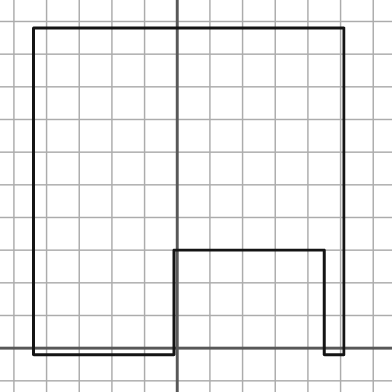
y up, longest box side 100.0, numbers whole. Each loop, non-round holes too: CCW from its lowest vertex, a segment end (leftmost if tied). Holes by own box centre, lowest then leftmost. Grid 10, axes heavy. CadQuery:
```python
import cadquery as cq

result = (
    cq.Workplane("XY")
    .moveTo(-44.0, -2.0)
    .lineTo(-1.0, -2.0)
    .lineTo(-1.0, 30.0)
    .lineTo(45.0, 30.0)
    .lineTo(45.0, -2.0)
    .lineTo(51.0, -2.0)
    .lineTo(51.0, 98.0)
    .lineTo(-44.0, 98.0)
    .close()
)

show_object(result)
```